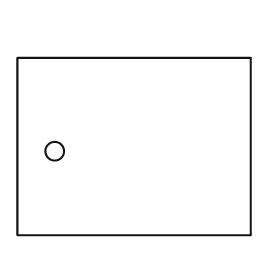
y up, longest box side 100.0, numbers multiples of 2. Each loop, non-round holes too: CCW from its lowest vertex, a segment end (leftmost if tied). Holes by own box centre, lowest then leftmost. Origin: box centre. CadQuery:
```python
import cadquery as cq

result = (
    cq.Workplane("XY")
    .moveTo(-50.0, -38.0)
    .lineTo(50.0, -38.0)
    .lineTo(50.0, 38.0)
    .lineTo(-50.0, 38.0)
    .close()
    .moveTo(-34.0, -2.0)
    .circle(4.0)
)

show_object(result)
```